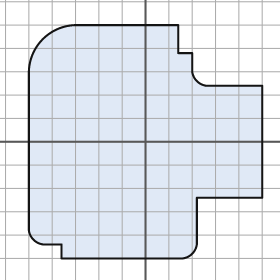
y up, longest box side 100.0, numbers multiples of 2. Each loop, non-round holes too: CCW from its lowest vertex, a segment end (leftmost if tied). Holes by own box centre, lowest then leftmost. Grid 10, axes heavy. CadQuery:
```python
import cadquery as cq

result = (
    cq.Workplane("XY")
    .moveTo(-36.0, -50.0)
    .lineTo(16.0, -50.0)
    .threePointArc((20.0, -48.0), (22.0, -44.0))
    .lineTo(22.0, -24.0)
    .lineTo(50.0, -24.0)
    .lineTo(50.0, 24.0)
    .lineTo(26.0, 24.0)
    .threePointArc((22.0, 26.0), (20.0, 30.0))
    .lineTo(20.0, 38.0)
    .lineTo(14.0, 38.0)
    .lineTo(14.0, 50.0)
    .lineTo(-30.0, 50.0)
    .threePointArc((-44.0, 44.0), (-50.0, 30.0))
    .lineTo(-50.0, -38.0)
    .threePointArc((-48.0, -42.0), (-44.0, -44.0))
    .lineTo(-36.0, -44.0)
    .close()
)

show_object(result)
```